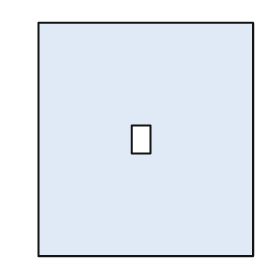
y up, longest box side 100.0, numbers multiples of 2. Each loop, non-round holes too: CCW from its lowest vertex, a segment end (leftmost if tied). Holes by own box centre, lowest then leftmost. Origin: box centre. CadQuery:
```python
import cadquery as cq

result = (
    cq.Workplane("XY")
    .moveTo(-46.0, -50.0)
    .lineTo(46.0, -50.0)
    .lineTo(46.0, 50.0)
    .lineTo(-46.0, 50.0)
    .close()
    .moveTo(-6.0, -6.0)
    .lineTo(2.0, -6.0)
    .lineTo(2.0, 6.0)
    .lineTo(-6.0, 6.0)
    .close()
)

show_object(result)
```